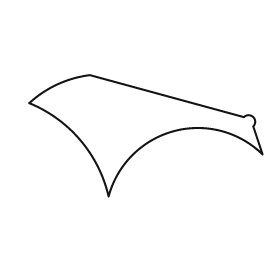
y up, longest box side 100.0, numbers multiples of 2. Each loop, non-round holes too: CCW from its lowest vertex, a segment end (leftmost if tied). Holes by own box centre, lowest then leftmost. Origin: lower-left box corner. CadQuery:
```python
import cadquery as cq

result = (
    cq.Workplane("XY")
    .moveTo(34.0, 0.0)
    .threePointArc((62.0, 28.0), (100.0, 18.0))
    .lineTo(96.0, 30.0)
    .threePointArc((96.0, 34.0), (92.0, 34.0))
    .lineTo(26.0, 52.0)
    .threePointArc((12.0, 48.0), (0.0, 40.0))
    .threePointArc((22.0, 24.0), (34.0, 0.0))
    .close()
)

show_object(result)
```